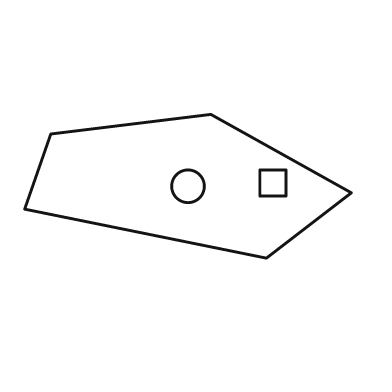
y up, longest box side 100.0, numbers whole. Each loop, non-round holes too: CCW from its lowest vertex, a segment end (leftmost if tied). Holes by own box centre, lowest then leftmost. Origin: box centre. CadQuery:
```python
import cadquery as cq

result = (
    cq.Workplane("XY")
    .moveTo(24.0, -22.0)
    .lineTo(50.0, -2.0)
    .lineTo(7.0, 22.0)
    .lineTo(-42.0, 16.0)
    .lineTo(-50.0, -7.0)
    .close()
    .moveTo(0.0, 0.0)
    .circle(5.0)
    .moveTo(22.0, -3.0)
    .lineTo(30.0, -3.0)
    .lineTo(30.0, 5.0)
    .lineTo(22.0, 5.0)
    .close()
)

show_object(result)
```